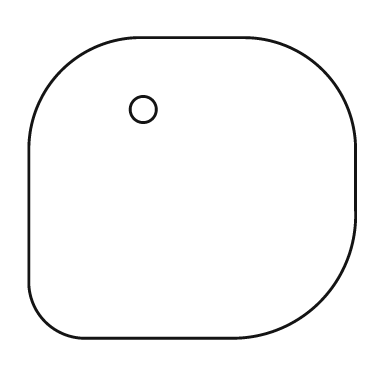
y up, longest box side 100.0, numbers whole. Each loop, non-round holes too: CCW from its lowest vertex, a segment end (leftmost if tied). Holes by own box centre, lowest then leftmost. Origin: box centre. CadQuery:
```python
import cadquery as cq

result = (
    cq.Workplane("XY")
    .moveTo(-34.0, -46.0)
    .lineTo(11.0, -46.0)
    .threePointArc((39.0, -35.0), (50.0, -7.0))
    .lineTo(50.0, 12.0)
    .threePointArc((40.0, 36.0), (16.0, 46.0))
    .lineTo(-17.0, 46.0)
    .threePointArc((-40.0, 36.0), (-50.0, 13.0))
    .lineTo(-50.0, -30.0)
    .threePointArc((-45.0, -41.0), (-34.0, -46.0))
    .close()
    .moveTo(-15.0, 24.0)
    .circle(4.0)
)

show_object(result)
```